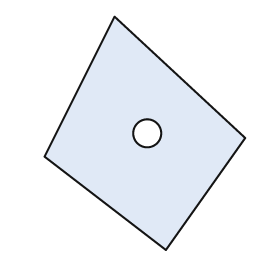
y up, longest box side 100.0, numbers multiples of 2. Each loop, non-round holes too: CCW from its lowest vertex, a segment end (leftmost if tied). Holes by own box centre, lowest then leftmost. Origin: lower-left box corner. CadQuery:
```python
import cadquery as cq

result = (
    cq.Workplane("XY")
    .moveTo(52.0, 0.0)
    .lineTo(86.0, 48.0)
    .lineTo(30.0, 100.0)
    .lineTo(0.0, 40.0)
    .close()
    .moveTo(44.0, 50.0)
    .circle(6.0)
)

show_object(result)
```